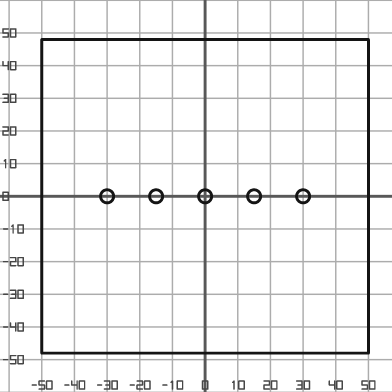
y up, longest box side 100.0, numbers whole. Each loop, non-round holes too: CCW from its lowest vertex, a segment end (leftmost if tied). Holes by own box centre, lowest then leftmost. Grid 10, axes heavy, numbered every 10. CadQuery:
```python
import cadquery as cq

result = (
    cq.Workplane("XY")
    .moveTo(-50.0, -48.0)
    .lineTo(50.0, -48.0)
    .lineTo(50.0, 48.0)
    .lineTo(-50.0, 48.0)
    .close()
    .moveTo(-30.0, 0.0)
    .circle(2.0)
    .moveTo(-15.0, 0.0)
    .circle(2.0)
    .moveTo(0.0, 0.0)
    .circle(2.0)
    .moveTo(15.0, 0.0)
    .circle(2.0)
    .moveTo(30.0, 0.0)
    .circle(2.0)
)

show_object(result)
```